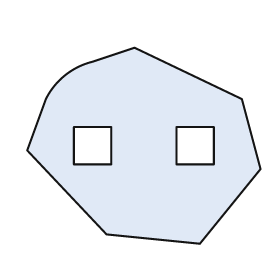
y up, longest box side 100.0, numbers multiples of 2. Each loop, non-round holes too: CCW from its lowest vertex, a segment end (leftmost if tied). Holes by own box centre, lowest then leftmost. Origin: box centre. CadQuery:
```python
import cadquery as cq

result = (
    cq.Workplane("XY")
    .moveTo(24.0, -42.0)
    .lineTo(50.0, -10.0)
    .lineTo(42.0, 20.0)
    .lineTo(-4.0, 42.0)
    .lineTo(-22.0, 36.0)
    .threePointArc((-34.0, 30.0), (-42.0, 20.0))
    .lineTo(-50.0, -2.0)
    .lineTo(-16.0, -38.0)
    .close()
    .moveTo(-30.0, -8.0)
    .lineTo(-14.0, -8.0)
    .lineTo(-14.0, 8.0)
    .lineTo(-30.0, 8.0)
    .close()
    .moveTo(14.0, -8.0)
    .lineTo(30.0, -8.0)
    .lineTo(30.0, 8.0)
    .lineTo(14.0, 8.0)
    .close()
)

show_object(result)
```